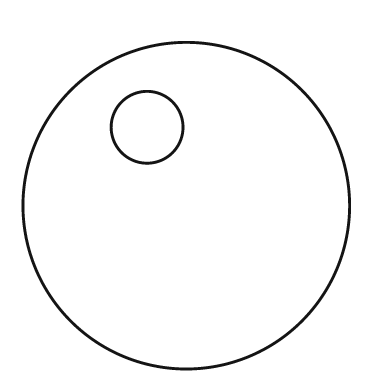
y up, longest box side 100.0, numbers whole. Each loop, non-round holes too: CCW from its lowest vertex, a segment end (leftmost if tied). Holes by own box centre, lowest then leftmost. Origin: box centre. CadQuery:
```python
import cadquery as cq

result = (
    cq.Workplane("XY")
    .moveTo(0.0, 0.0)
    .circle(50.0)
    .moveTo(-12.0, 24.0)
    .circle(11.0)
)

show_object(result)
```